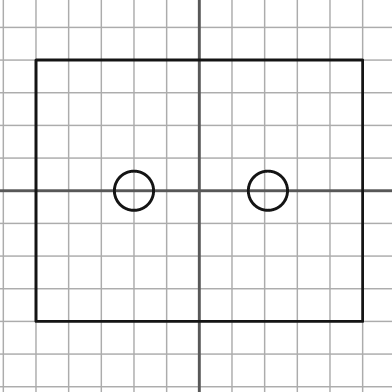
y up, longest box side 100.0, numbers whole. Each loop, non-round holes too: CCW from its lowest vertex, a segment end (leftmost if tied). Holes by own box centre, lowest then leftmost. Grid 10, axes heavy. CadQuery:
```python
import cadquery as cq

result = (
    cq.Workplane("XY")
    .moveTo(-50.0, -40.0)
    .lineTo(50.0, -40.0)
    .lineTo(50.0, 40.0)
    .lineTo(-50.0, 40.0)
    .close()
    .moveTo(-20.0, 0.0)
    .circle(6.0)
    .moveTo(21.0, 0.0)
    .circle(6.0)
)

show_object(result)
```